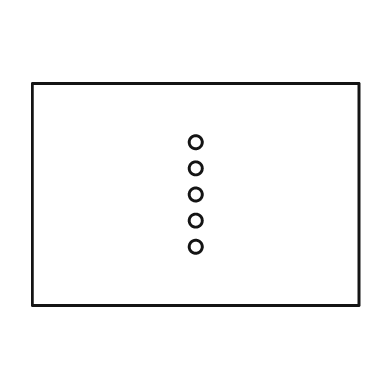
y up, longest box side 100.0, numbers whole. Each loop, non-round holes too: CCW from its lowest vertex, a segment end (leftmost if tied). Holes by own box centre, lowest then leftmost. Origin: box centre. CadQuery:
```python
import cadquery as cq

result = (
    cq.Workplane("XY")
    .moveTo(-50.0, -34.0)
    .lineTo(50.0, -34.0)
    .lineTo(50.0, 34.0)
    .lineTo(-50.0, 34.0)
    .close()
    .moveTo(0.0, -16.0)
    .circle(2.0)
    .moveTo(0.0, -8.0)
    .circle(2.0)
    .moveTo(0.0, 0.0)
    .circle(2.0)
    .moveTo(0.0, 8.0)
    .circle(2.0)
    .moveTo(0.0, 16.0)
    .circle(2.0)
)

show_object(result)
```